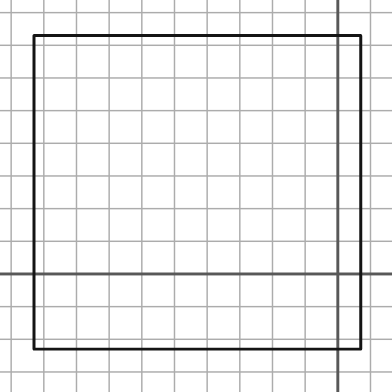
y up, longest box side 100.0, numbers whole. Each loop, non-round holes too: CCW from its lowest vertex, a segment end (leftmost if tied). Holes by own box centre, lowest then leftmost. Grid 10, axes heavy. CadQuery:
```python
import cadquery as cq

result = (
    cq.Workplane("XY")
    .moveTo(-93.0, -23.0)
    .lineTo(7.0, -23.0)
    .lineTo(7.0, 73.0)
    .lineTo(-93.0, 73.0)
    .close()
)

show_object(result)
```